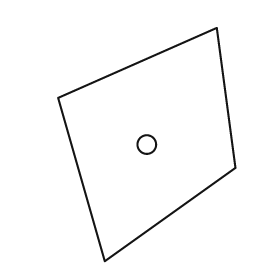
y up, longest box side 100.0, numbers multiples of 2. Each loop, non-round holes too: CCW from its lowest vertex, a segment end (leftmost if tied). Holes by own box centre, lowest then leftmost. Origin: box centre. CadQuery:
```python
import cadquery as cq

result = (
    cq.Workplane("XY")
    .moveTo(-18.0, -50.0)
    .lineTo(38.0, -10.0)
    .lineTo(30.0, 50.0)
    .lineTo(-38.0, 20.0)
    .close()
    .moveTo(0.0, 0.0)
    .circle(4.0)
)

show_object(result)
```